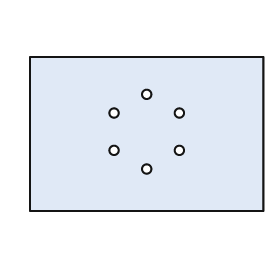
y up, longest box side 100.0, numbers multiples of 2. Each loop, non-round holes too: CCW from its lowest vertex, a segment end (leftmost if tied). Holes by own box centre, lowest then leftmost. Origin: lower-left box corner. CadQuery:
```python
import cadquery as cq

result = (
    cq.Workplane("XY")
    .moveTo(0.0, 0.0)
    .lineTo(100.0, 0.0)
    .lineTo(100.0, 66.0)
    .lineTo(0.0, 66.0)
    .close()
    .moveTo(50.0, 18.0)
    .circle(2.0)
    .moveTo(36.0, 26.0)
    .circle(2.0)
    .moveTo(64.0, 26.0)
    .circle(2.0)
    .moveTo(36.0, 42.0)
    .circle(2.0)
    .moveTo(64.0, 42.0)
    .circle(2.0)
    .moveTo(50.0, 50.0)
    .circle(2.0)
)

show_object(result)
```